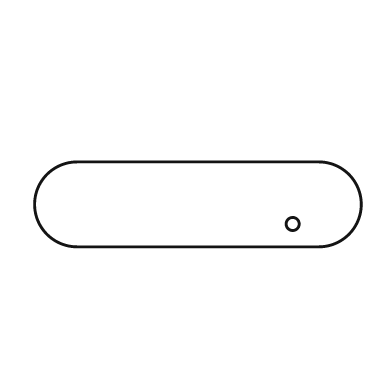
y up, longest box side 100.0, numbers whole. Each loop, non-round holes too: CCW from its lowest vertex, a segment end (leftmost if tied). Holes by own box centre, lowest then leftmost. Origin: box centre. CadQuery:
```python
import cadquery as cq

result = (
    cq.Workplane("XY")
    .moveTo(-37.0, -13.0)
    .lineTo(37.0, -13.0)
    .threePointArc((50.0, 0.0), (37.0, 13.0))
    .lineTo(-37.0, 13.0)
    .threePointArc((-50.0, 0.0), (-37.0, -13.0))
    .close()
    .moveTo(29.0, -6.0)
    .circle(2.0)
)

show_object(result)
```